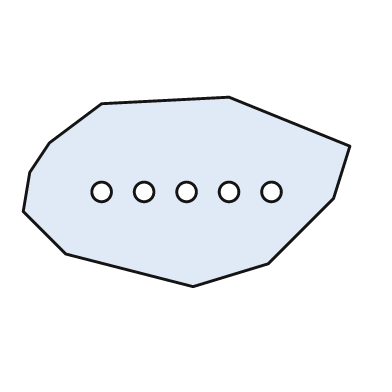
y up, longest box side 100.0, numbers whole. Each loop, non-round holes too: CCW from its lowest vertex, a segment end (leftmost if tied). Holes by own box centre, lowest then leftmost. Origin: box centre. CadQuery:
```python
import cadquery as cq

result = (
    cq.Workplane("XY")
    .moveTo(2.0, -29.0)
    .lineTo(25.0, -22.0)
    .lineTo(45.0, -2.0)
    .lineTo(50.0, 14.0)
    .lineTo(13.0, 29.0)
    .lineTo(-26.0, 27.0)
    .lineTo(-42.0, 15.0)
    .lineTo(-48.0, 6.0)
    .lineTo(-50.0, -6.0)
    .lineTo(-37.0, -19.0)
    .close()
    .moveTo(-26.0, 0.0)
    .circle(3.0)
    .moveTo(-13.0, 0.0)
    .circle(3.0)
    .moveTo(0.0, 0.0)
    .circle(3.0)
    .moveTo(13.0, 0.0)
    .circle(3.0)
    .moveTo(26.0, 0.0)
    .circle(3.0)
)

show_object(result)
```